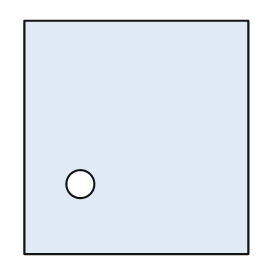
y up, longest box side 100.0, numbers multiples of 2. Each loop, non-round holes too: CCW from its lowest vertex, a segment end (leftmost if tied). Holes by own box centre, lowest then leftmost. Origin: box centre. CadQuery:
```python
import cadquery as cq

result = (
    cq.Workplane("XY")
    .moveTo(-48.0, -50.0)
    .lineTo(48.0, -50.0)
    .lineTo(48.0, 50.0)
    .lineTo(-48.0, 50.0)
    .close()
    .moveTo(-24.0, -20.0)
    .circle(6.0)
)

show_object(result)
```